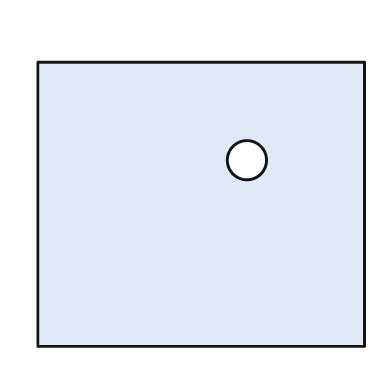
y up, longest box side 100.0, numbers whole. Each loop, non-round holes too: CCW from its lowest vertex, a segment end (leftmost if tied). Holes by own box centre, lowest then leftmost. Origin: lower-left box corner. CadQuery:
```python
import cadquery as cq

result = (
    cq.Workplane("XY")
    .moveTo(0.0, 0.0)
    .lineTo(100.0, 0.0)
    .lineTo(100.0, 87.0)
    .lineTo(0.0, 87.0)
    .close()
    .moveTo(64.0, 57.0)
    .circle(6.0)
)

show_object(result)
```